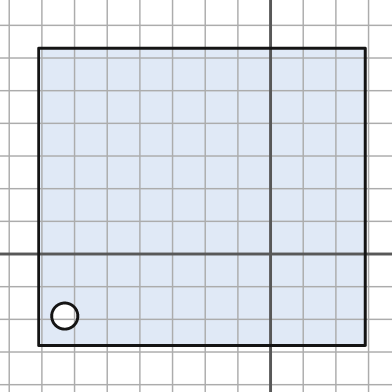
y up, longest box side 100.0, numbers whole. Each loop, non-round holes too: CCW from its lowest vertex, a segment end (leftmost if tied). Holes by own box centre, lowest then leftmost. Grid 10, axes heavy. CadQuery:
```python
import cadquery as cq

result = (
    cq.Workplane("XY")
    .moveTo(-71.0, -28.0)
    .lineTo(29.0, -28.0)
    .lineTo(29.0, 63.0)
    .lineTo(-71.0, 63.0)
    .close()
    .moveTo(-63.0, -19.0)
    .circle(4.0)
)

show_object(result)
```